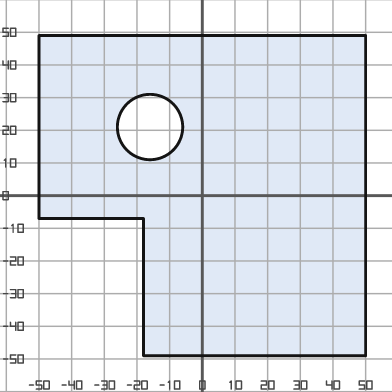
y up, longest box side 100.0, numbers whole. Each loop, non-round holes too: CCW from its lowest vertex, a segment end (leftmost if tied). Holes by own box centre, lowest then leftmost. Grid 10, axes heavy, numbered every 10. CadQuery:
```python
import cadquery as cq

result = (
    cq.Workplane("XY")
    .moveTo(-18.0, -49.0)
    .lineTo(50.0, -49.0)
    .lineTo(50.0, 49.0)
    .lineTo(-50.0, 49.0)
    .lineTo(-50.0, -7.0)
    .lineTo(-18.0, -7.0)
    .close()
    .moveTo(-16.0, 21.0)
    .circle(10.0)
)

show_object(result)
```